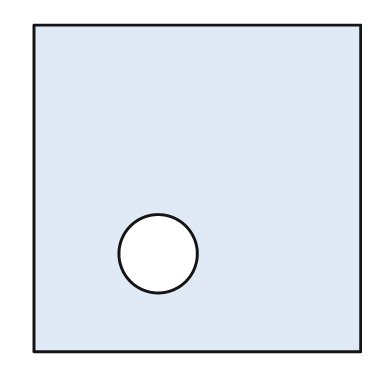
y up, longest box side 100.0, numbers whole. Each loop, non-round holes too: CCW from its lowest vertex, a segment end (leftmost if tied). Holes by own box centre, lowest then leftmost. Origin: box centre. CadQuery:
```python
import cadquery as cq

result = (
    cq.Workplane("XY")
    .moveTo(-50.0, -50.0)
    .lineTo(50.0, -50.0)
    .lineTo(50.0, 50.0)
    .lineTo(-50.0, 50.0)
    .close()
    .moveTo(-12.0, -20.0)
    .circle(12.0)
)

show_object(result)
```